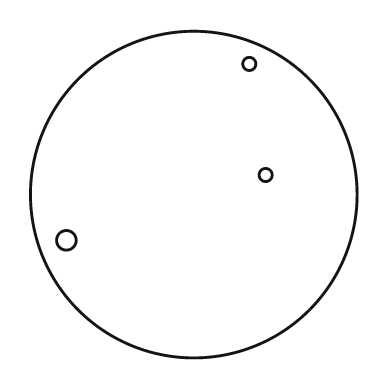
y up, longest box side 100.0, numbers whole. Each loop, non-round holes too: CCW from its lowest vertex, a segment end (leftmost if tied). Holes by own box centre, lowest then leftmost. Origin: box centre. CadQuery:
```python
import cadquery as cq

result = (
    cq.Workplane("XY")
    .moveTo(0.0, 0.0)
    .circle(50.0)
    .moveTo(-39.0, -14.0)
    .circle(3.0)
    .moveTo(22.0, 6.0)
    .circle(2.0)
    .moveTo(17.0, 40.0)
    .circle(2.0)
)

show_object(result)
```